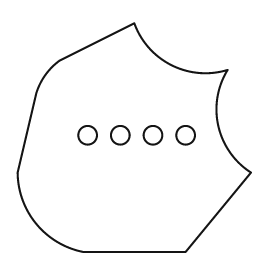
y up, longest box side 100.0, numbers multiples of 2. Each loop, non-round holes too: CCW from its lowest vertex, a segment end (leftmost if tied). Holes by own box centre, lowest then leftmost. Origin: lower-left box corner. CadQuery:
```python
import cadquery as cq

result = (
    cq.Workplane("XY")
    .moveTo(28.0, 0.0)
    .lineTo(72.0, 0.0)
    .lineTo(100.0, 34.0)
    .threePointArc((86.0, 54.0), (90.0, 78.0))
    .threePointArc((66.0, 80.0), (50.0, 98.0))
    .lineTo(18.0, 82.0)
    .threePointArc((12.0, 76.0), (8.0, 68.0))
    .lineTo(0.0, 34.0)
    .threePointArc((8.0, 12.0), (28.0, 0.0))
    .close()
    .moveTo(30.0, 50.0)
    .circle(4.0)
    .moveTo(44.0, 50.0)
    .circle(4.0)
    .moveTo(58.0, 50.0)
    .circle(4.0)
    .moveTo(72.0, 50.0)
    .circle(4.0)
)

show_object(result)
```